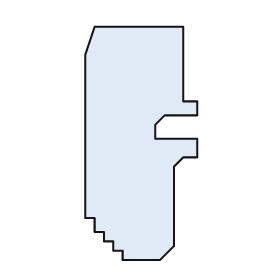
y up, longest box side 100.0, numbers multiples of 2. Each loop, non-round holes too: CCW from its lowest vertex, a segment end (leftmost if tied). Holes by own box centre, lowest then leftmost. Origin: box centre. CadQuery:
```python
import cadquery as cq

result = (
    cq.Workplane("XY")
    .moveTo(-8.0, -50.0)
    .lineTo(8.0, -50.0)
    .lineTo(14.0, -44.0)
    .lineTo(14.0, -10.0)
    .lineTo(18.0, -6.0)
    .lineTo(24.0, -6.0)
    .lineTo(24.0, 2.0)
    .lineTo(6.0, 2.0)
    .lineTo(6.0, 8.0)
    .lineTo(10.0, 12.0)
    .lineTo(24.0, 12.0)
    .lineTo(24.0, 18.0)
    .lineTo(18.0, 18.0)
    .lineTo(18.0, 50.0)
    .lineTo(-20.0, 50.0)
    .lineTo(-24.0, 38.0)
    .lineTo(-24.0, -32.0)
    .lineTo(-20.0, -32.0)
    .lineTo(-20.0, -38.0)
    .lineTo(-16.0, -38.0)
    .lineTo(-16.0, -42.0)
    .lineTo(-12.0, -42.0)
    .lineTo(-12.0, -46.0)
    .lineTo(-8.0, -46.0)
    .close()
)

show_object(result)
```